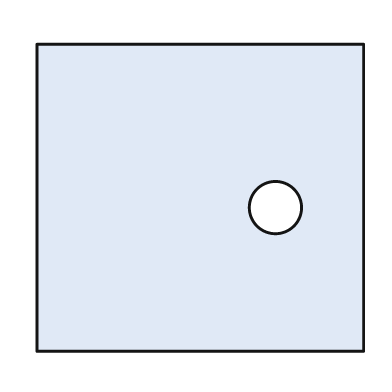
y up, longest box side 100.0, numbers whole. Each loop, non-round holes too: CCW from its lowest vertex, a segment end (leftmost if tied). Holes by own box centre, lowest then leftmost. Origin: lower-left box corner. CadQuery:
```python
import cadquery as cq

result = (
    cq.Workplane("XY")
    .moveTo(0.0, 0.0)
    .lineTo(100.0, 0.0)
    .lineTo(100.0, 94.0)
    .lineTo(0.0, 94.0)
    .close()
    .moveTo(73.0, 44.0)
    .circle(8.0)
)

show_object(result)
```